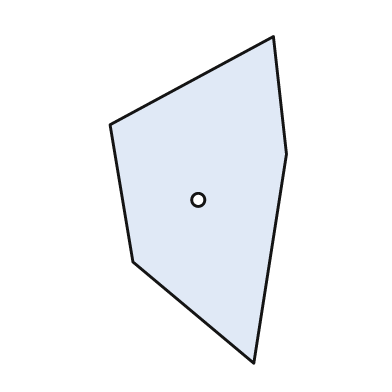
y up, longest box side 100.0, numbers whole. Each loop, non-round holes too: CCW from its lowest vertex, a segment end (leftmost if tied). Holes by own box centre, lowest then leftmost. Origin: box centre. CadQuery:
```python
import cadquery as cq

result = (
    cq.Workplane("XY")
    .moveTo(17.0, -50.0)
    .lineTo(27.0, 14.0)
    .lineTo(23.0, 50.0)
    .lineTo(-27.0, 23.0)
    .lineTo(-20.0, -19.0)
    .close()
    .moveTo(0.0, 0.0)
    .circle(2.0)
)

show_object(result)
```